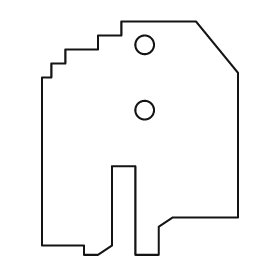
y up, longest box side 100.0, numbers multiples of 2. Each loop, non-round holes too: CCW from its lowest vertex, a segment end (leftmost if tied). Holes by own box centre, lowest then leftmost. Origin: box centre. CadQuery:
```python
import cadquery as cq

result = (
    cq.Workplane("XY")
    .moveTo(-24.0, -50.0)
    .lineTo(-18.0, -50.0)
    .lineTo(-12.0, -46.0)
    .lineTo(-12.0, -12.0)
    .lineTo(-2.0, -12.0)
    .lineTo(-2.0, -50.0)
    .lineTo(8.0, -50.0)
    .lineTo(8.0, -38.0)
    .lineTo(14.0, -34.0)
    .lineTo(42.0, -34.0)
    .lineTo(42.0, 28.0)
    .lineTo(24.0, 50.0)
    .lineTo(-8.0, 50.0)
    .lineTo(-8.0, 44.0)
    .lineTo(-18.0, 44.0)
    .lineTo(-18.0, 38.0)
    .lineTo(-32.0, 38.0)
    .lineTo(-32.0, 32.0)
    .lineTo(-38.0, 32.0)
    .lineTo(-38.0, 26.0)
    .lineTo(-42.0, 26.0)
    .lineTo(-42.0, -46.0)
    .lineTo(-24.0, -46.0)
    .close()
    .moveTo(2.0, 12.0)
    .circle(4.0)
    .moveTo(2.0, 40.0)
    .circle(4.0)
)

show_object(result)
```